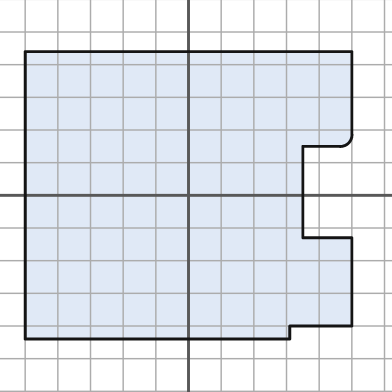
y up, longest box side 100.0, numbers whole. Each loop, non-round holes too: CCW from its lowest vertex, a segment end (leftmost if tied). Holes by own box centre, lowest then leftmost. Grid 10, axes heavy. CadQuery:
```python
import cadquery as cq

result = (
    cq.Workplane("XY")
    .moveTo(-50.0, -44.0)
    .lineTo(31.0, -44.0)
    .lineTo(31.0, -40.0)
    .lineTo(50.0, -40.0)
    .lineTo(50.0, -13.0)
    .lineTo(35.0, -13.0)
    .lineTo(35.0, 15.0)
    .lineTo(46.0, 15.0)
    .threePointArc((49.0, 16.0), (50.0, 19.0))
    .lineTo(50.0, 44.0)
    .lineTo(-50.0, 44.0)
    .close()
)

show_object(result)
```